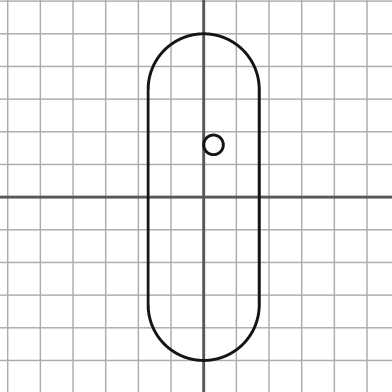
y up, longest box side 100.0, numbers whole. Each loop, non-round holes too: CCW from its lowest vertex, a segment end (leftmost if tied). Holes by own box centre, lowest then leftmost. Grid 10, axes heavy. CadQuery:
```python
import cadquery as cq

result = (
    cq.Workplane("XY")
    .moveTo(-17.0, -33.0)
    .threePointArc((0.0, -50.0), (17.0, -33.0))
    .lineTo(17.0, 33.0)
    .threePointArc((0.0, 50.0), (-17.0, 33.0))
    .close()
    .moveTo(3.0, 16.0)
    .circle(3.0)
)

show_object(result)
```